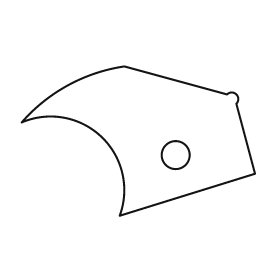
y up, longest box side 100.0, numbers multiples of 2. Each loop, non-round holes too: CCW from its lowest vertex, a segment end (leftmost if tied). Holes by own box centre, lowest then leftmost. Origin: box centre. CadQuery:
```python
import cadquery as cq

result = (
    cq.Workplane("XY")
    .moveTo(-8.0, -32.0)
    .lineTo(50.0, -14.0)
    .lineTo(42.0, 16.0)
    .threePointArc((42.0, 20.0), (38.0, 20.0))
    .lineTo(-6.0, 32.0)
    .threePointArc((-30.0, 24.0), (-50.0, 8.0))
    .threePointArc((-16.0, 2.0), (-8.0, -32.0))
    .close()
    .moveTo(16.0, -6.0)
    .circle(6.0)
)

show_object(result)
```